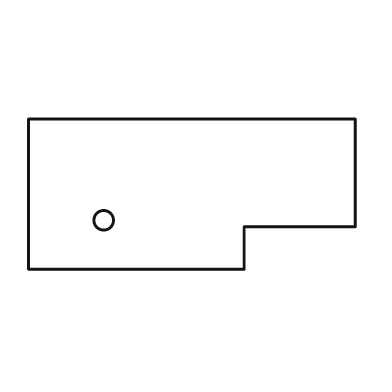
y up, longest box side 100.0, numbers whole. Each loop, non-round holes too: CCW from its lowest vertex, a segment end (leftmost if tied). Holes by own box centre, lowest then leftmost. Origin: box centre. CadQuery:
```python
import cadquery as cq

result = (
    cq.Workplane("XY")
    .moveTo(-50.0, -23.0)
    .lineTo(16.0, -23.0)
    .lineTo(16.0, -10.0)
    .lineTo(50.0, -10.0)
    .lineTo(50.0, 23.0)
    .lineTo(-50.0, 23.0)
    .close()
    .moveTo(-27.0, -8.0)
    .circle(3.0)
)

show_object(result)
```